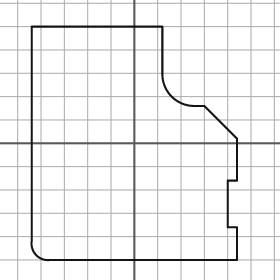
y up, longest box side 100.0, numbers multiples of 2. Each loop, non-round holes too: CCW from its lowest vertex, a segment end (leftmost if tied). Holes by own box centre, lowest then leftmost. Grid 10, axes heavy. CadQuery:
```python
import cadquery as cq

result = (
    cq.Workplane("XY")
    .moveTo(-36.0, -50.0)
    .lineTo(44.0, -50.0)
    .lineTo(44.0, -36.0)
    .lineTo(40.0, -36.0)
    .lineTo(40.0, -16.0)
    .lineTo(44.0, -16.0)
    .lineTo(44.0, 2.0)
    .lineTo(30.0, 16.0)
    .lineTo(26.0, 16.0)
    .threePointArc((16.0, 20.0), (12.0, 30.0))
    .lineTo(12.0, 50.0)
    .lineTo(-44.0, 50.0)
    .lineTo(-44.0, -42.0)
    .threePointArc((-42.0, -48.0), (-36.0, -50.0))
    .close()
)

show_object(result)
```